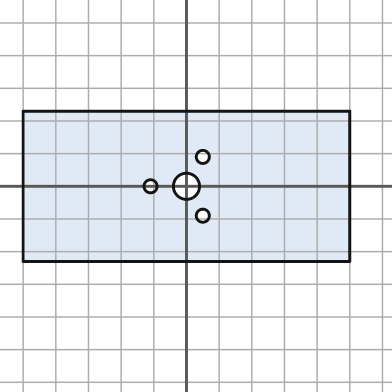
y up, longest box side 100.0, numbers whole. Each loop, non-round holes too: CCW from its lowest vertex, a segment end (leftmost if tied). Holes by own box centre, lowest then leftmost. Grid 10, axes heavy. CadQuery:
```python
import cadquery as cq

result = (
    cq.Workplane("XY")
    .moveTo(-50.0, -23.0)
    .lineTo(50.0, -23.0)
    .lineTo(50.0, 23.0)
    .lineTo(-50.0, 23.0)
    .close()
    .moveTo(5.0, -9.0)
    .circle(2.0)
    .moveTo(-11.0, 0.0)
    .circle(2.0)
    .moveTo(0.0, 0.0)
    .circle(4.0)
    .moveTo(5.0, 9.0)
    .circle(2.0)
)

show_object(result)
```